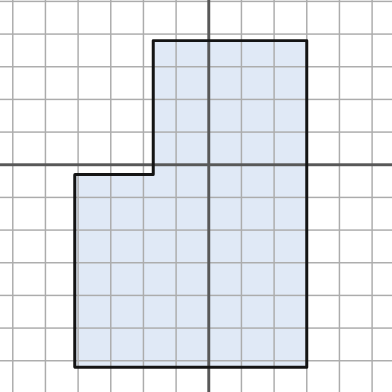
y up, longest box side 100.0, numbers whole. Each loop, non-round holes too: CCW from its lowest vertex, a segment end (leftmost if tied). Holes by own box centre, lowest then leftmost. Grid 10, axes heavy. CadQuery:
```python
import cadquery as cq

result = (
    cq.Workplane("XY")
    .moveTo(-41.0, -62.0)
    .lineTo(30.0, -62.0)
    .lineTo(30.0, 38.0)
    .lineTo(-17.0, 38.0)
    .lineTo(-17.0, -3.0)
    .lineTo(-41.0, -3.0)
    .close()
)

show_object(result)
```